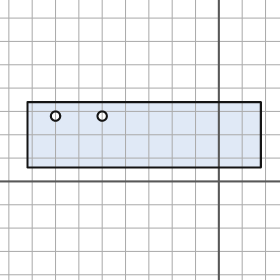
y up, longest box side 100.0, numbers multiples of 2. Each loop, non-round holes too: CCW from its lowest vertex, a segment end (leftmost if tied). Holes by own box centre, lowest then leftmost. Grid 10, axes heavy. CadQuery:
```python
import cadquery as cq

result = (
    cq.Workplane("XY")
    .moveTo(-82.0, 6.0)
    .lineTo(18.0, 6.0)
    .lineTo(18.0, 34.0)
    .lineTo(-82.0, 34.0)
    .close()
    .moveTo(-70.0, 28.0)
    .circle(2.0)
    .moveTo(-50.0, 28.0)
    .circle(2.0)
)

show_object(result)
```